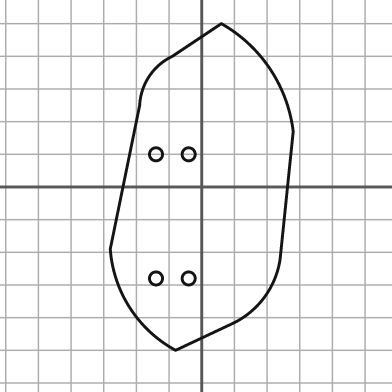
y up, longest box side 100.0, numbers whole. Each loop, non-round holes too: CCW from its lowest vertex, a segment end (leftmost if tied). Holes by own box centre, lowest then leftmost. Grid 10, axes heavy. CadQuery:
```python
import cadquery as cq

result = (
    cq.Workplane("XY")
    .moveTo(-8.0, -50.0)
    .lineTo(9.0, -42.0)
    .threePointArc((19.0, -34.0), (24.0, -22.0))
    .lineTo(28.0, 17.0)
    .threePointArc((21.0, 36.0), (6.0, 50.0))
    .lineTo(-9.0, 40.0)
    .threePointArc((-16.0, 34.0), (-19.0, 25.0))
    .lineTo(-28.0, -19.0)
    .threePointArc((-22.0, -37.0), (-8.0, -50.0))
    .close()
    .moveTo(-14.0, -28.0)
    .circle(2.0)
    .moveTo(-4.0, -28.0)
    .circle(2.0)
    .moveTo(-14.0, 10.0)
    .circle(2.0)
    .moveTo(-4.0, 10.0)
    .circle(2.0)
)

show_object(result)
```